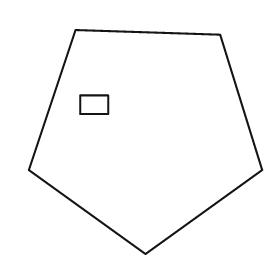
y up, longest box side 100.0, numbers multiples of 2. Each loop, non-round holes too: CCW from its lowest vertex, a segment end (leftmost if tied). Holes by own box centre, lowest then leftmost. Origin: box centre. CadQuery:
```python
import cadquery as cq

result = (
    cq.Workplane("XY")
    .moveTo(0.0, -48.0)
    .lineTo(50.0, -12.0)
    .lineTo(32.0, 46.0)
    .lineTo(-30.0, 48.0)
    .lineTo(-50.0, -12.0)
    .close()
    .moveTo(-28.0, 12.0)
    .lineTo(-16.0, 12.0)
    .lineTo(-16.0, 20.0)
    .lineTo(-28.0, 20.0)
    .close()
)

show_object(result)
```